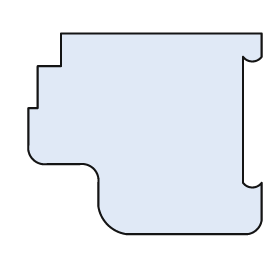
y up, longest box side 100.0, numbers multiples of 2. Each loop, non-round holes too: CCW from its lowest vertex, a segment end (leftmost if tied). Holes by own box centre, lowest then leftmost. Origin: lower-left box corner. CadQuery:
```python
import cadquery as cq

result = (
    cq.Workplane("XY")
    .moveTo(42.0, 0.0)
    .lineTo(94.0, 0.0)
    .threePointArc((98.0, 2.0), (100.0, 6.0))
    .lineTo(100.0, 22.0)
    .threePointArc((96.0, 20.0), (92.0, 22.0))
    .lineTo(92.0, 76.0)
    .threePointArc((96.0, 74.0), (100.0, 76.0))
    .lineTo(100.0, 86.0)
    .lineTo(14.0, 86.0)
    .lineTo(14.0, 72.0)
    .lineTo(4.0, 72.0)
    .lineTo(4.0, 54.0)
    .lineTo(0.0, 54.0)
    .lineTo(0.0, 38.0)
    .threePointArc((2.0, 32.0), (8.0, 30.0))
    .lineTo(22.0, 30.0)
    .threePointArc((28.0, 28.0), (30.0, 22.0))
    .lineTo(30.0, 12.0)
    .threePointArc((34.0, 4.0), (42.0, 0.0))
    .close()
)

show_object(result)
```